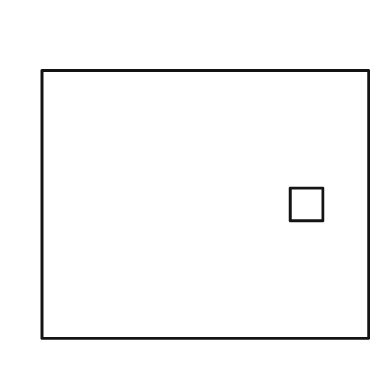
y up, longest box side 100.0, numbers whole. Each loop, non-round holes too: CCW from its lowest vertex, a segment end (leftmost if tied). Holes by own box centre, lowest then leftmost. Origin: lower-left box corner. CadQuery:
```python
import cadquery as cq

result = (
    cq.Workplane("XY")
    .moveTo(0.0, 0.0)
    .lineTo(100.0, 0.0)
    .lineTo(100.0, 82.0)
    .lineTo(0.0, 82.0)
    .close()
    .moveTo(76.0, 36.0)
    .lineTo(86.0, 36.0)
    .lineTo(86.0, 46.0)
    .lineTo(76.0, 46.0)
    .close()
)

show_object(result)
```